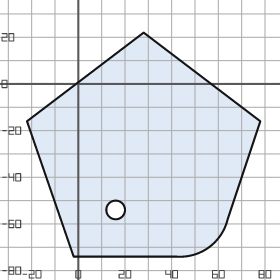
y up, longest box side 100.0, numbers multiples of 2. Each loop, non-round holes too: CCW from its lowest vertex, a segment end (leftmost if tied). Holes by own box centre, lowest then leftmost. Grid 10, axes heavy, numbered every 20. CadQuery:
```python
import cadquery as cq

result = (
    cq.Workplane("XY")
    .moveTo(-2.0, -74.0)
    .lineTo(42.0, -74.0)
    .threePointArc((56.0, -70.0), (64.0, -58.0))
    .lineTo(78.0, -16.0)
    .lineTo(28.0, 22.0)
    .lineTo(-22.0, -16.0)
    .close()
    .moveTo(16.0, -54.0)
    .circle(4.0)
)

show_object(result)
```